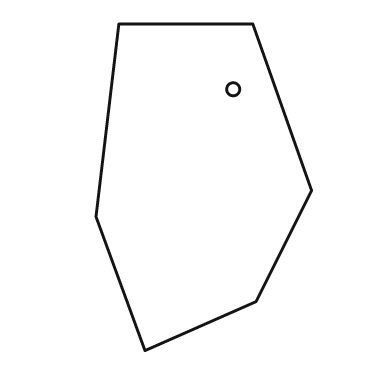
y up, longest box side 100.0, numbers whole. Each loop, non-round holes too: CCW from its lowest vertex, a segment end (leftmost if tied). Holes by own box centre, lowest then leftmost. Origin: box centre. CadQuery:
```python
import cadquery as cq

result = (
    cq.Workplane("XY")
    .moveTo(-18.0, -50.0)
    .lineTo(16.0, -35.0)
    .lineTo(33.0, -1.0)
    .lineTo(15.0, 50.0)
    .lineTo(-26.0, 50.0)
    .lineTo(-33.0, -9.0)
    .close()
    .moveTo(9.0, 30.0)
    .circle(2.0)
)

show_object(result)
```